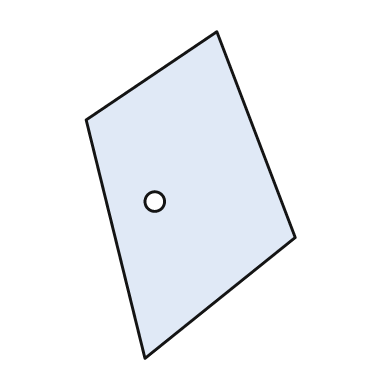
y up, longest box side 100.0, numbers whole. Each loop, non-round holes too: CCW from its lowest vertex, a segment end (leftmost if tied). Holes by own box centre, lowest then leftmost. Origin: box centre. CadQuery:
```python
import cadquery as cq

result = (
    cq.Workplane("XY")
    .moveTo(-14.0, -50.0)
    .lineTo(32.0, -13.0)
    .lineTo(8.0, 50.0)
    .lineTo(-32.0, 23.0)
    .close()
    .moveTo(-11.0, -2.0)
    .circle(3.0)
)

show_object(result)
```